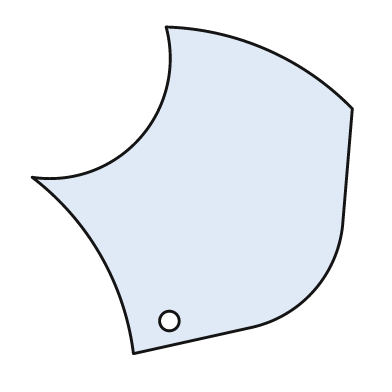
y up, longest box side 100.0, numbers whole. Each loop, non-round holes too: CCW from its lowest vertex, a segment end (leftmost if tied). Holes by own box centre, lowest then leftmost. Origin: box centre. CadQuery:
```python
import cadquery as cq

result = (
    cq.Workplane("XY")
    .moveTo(-18.0, -50.0)
    .lineTo(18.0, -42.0)
    .threePointArc((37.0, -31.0), (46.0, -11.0))
    .lineTo(49.0, 25.0)
    .threePointArc((23.0, 43.0), (-8.0, 50.0))
    .threePointArc((-16.0, 16.0), (-49.0, 4.0))
    .threePointArc((-28.0, -20.0), (-18.0, -50.0))
    .close()
    .moveTo(-7.0, -40.0)
    .circle(3.0)
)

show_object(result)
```